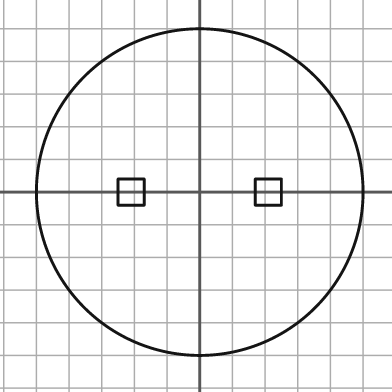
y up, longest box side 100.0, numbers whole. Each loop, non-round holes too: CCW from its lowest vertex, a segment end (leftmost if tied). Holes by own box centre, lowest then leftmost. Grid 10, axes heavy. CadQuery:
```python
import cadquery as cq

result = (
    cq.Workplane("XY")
    .moveTo(0.0, 0.0)
    .circle(50.0)
    .moveTo(-25.0, -4.0)
    .lineTo(-17.0, -4.0)
    .lineTo(-17.0, 4.0)
    .lineTo(-25.0, 4.0)
    .close()
    .moveTo(17.0, -4.0)
    .lineTo(25.0, -4.0)
    .lineTo(25.0, 4.0)
    .lineTo(17.0, 4.0)
    .close()
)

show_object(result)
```